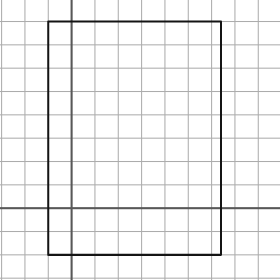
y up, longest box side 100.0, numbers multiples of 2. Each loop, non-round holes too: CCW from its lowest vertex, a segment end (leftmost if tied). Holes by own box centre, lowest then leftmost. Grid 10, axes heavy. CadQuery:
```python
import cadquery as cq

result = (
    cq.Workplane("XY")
    .moveTo(-10.0, -20.0)
    .lineTo(64.0, -20.0)
    .lineTo(64.0, 80.0)
    .lineTo(-10.0, 80.0)
    .close()
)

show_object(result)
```